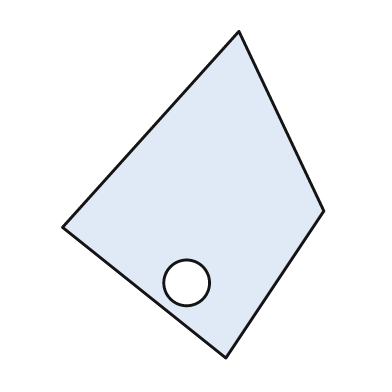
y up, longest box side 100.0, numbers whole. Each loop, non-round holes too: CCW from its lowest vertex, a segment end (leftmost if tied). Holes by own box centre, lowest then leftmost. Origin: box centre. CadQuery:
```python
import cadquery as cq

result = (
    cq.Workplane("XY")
    .moveTo(10.0, -50.0)
    .lineTo(40.0, -5.0)
    .lineTo(14.0, 50.0)
    .lineTo(-40.0, -10.0)
    .close()
    .moveTo(-2.0, -27.0)
    .circle(7.0)
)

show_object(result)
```